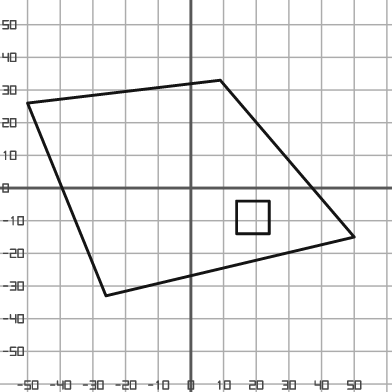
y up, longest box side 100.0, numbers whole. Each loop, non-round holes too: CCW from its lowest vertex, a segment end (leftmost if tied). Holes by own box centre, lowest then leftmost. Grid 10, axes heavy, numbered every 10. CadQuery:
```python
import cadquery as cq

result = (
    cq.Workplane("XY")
    .moveTo(-26.0, -33.0)
    .lineTo(50.0, -15.0)
    .lineTo(9.0, 33.0)
    .lineTo(-50.0, 26.0)
    .close()
    .moveTo(14.0, -14.0)
    .lineTo(24.0, -14.0)
    .lineTo(24.0, -4.0)
    .lineTo(14.0, -4.0)
    .close()
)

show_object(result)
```